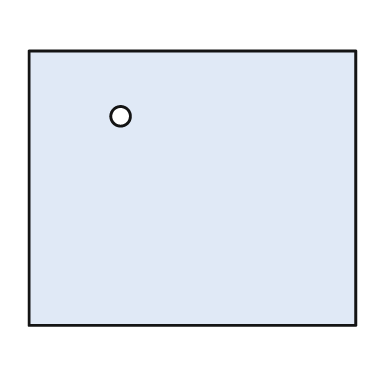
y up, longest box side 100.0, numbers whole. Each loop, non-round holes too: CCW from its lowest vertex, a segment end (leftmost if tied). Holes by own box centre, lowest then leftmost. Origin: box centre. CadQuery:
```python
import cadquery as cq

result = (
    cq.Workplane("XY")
    .moveTo(-50.0, -42.0)
    .lineTo(50.0, -42.0)
    .lineTo(50.0, 42.0)
    .lineTo(-50.0, 42.0)
    .close()
    .moveTo(-22.0, 22.0)
    .circle(3.0)
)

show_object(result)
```